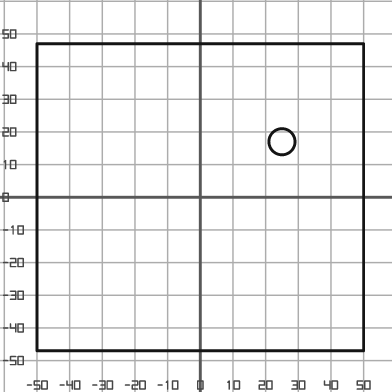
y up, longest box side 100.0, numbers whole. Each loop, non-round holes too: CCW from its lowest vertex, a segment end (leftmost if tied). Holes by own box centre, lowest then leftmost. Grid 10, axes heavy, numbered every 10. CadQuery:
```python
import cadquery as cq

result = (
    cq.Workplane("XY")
    .moveTo(-50.0, -47.0)
    .lineTo(50.0, -47.0)
    .lineTo(50.0, 47.0)
    .lineTo(-50.0, 47.0)
    .close()
    .moveTo(25.0, 17.0)
    .circle(4.0)
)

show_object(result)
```